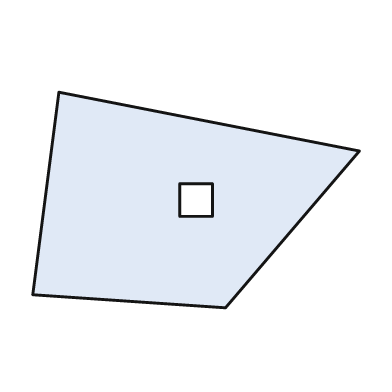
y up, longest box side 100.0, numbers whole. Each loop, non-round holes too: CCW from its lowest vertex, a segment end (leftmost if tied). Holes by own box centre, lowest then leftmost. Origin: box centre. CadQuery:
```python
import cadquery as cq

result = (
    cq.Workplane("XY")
    .moveTo(9.0, -33.0)
    .lineTo(50.0, 15.0)
    .lineTo(-42.0, 33.0)
    .lineTo(-50.0, -29.0)
    .close()
    .moveTo(-5.0, -5.0)
    .lineTo(5.0, -5.0)
    .lineTo(5.0, 5.0)
    .lineTo(-5.0, 5.0)
    .close()
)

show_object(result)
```